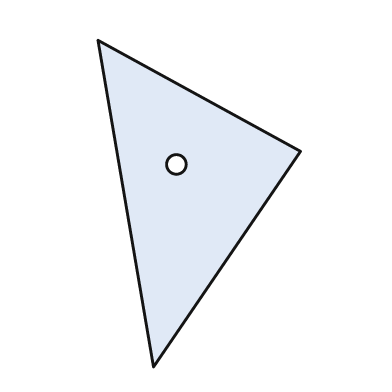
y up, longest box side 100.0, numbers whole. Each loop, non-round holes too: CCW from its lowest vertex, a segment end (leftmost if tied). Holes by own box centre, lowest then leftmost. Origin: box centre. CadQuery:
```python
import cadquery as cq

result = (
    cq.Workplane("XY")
    .moveTo(-14.0, -50.0)
    .lineTo(31.0, 16.0)
    .lineTo(-31.0, 50.0)
    .close()
    .moveTo(-7.0, 12.0)
    .circle(3.0)
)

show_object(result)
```